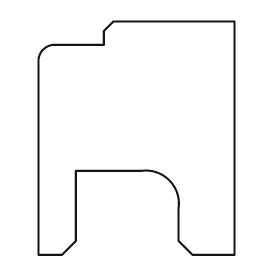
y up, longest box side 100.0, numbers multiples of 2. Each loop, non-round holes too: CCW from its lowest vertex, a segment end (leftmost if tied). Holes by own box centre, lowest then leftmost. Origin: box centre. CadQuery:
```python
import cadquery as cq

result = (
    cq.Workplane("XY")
    .moveTo(-42.0, -50.0)
    .lineTo(-32.0, -50.0)
    .lineTo(-26.0, -44.0)
    .lineTo(-26.0, -14.0)
    .lineTo(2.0, -14.0)
    .threePointArc((14.0, -18.0), (18.0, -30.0))
    .lineTo(18.0, -44.0)
    .lineTo(24.0, -50.0)
    .lineTo(42.0, -50.0)
    .lineTo(42.0, 50.0)
    .lineTo(-10.0, 50.0)
    .lineTo(-14.0, 46.0)
    .lineTo(-14.0, 40.0)
    .lineTo(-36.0, 40.0)
    .threePointArc((-40.0, 38.0), (-42.0, 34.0))
    .close()
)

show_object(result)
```